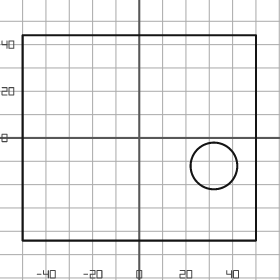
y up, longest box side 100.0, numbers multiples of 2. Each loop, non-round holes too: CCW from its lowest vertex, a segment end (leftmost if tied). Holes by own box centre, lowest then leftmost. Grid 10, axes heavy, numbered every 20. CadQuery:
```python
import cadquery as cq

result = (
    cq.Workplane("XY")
    .moveTo(-50.0, -44.0)
    .lineTo(50.0, -44.0)
    .lineTo(50.0, 44.0)
    .lineTo(-50.0, 44.0)
    .close()
    .moveTo(32.0, -12.0)
    .circle(10.0)
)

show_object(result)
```